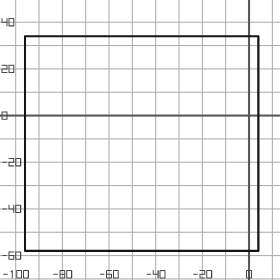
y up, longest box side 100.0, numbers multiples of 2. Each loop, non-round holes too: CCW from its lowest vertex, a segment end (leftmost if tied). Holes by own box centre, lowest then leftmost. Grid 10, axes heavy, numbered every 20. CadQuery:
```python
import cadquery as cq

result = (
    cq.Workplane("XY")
    .moveTo(-96.0, -58.0)
    .lineTo(4.0, -58.0)
    .lineTo(4.0, 34.0)
    .lineTo(-96.0, 34.0)
    .close()
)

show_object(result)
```